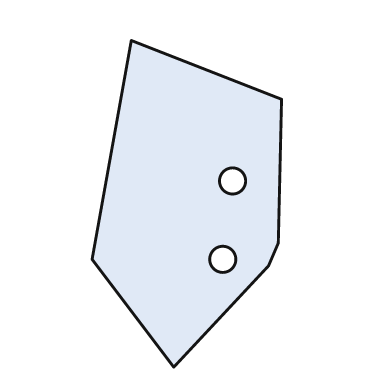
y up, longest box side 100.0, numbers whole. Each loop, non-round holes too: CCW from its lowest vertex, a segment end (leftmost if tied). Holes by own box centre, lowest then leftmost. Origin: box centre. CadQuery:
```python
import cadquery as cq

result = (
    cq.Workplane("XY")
    .moveTo(-4.0, -50.0)
    .lineTo(25.0, -19.0)
    .lineTo(28.0, -12.0)
    .lineTo(29.0, 32.0)
    .lineTo(-17.0, 50.0)
    .lineTo(-29.0, -17.0)
    .close()
    .moveTo(11.0, -17.0)
    .circle(4.0)
    .moveTo(14.0, 7.0)
    .circle(4.0)
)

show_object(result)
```